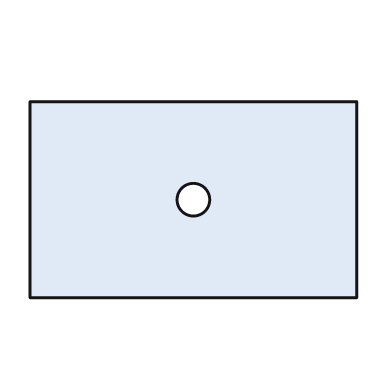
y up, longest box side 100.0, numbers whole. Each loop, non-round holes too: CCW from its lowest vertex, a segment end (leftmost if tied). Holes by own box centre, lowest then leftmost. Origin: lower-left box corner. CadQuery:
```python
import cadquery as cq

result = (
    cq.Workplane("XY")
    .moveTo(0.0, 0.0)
    .lineTo(100.0, 0.0)
    .lineTo(100.0, 60.0)
    .lineTo(0.0, 60.0)
    .close()
    .moveTo(50.0, 30.0)
    .circle(5.0)
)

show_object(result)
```